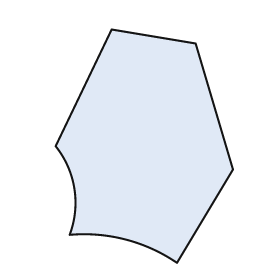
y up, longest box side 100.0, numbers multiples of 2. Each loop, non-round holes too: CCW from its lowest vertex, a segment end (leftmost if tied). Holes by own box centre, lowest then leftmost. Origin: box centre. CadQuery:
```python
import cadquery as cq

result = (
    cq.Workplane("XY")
    .moveTo(14.0, -50.0)
    .lineTo(38.0, -10.0)
    .lineTo(22.0, 44.0)
    .lineTo(-14.0, 50.0)
    .lineTo(-38.0, 0.0)
    .threePointArc((-30.0, -18.0), (-32.0, -38.0))
    .threePointArc((-8.0, -40.0), (14.0, -50.0))
    .close()
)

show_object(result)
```